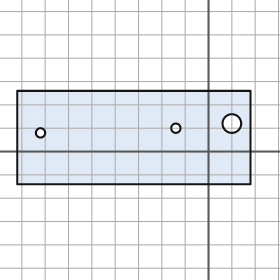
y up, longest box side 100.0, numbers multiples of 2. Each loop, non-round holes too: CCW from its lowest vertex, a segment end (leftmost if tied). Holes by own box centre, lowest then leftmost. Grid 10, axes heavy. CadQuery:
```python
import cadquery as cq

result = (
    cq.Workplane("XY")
    .moveTo(-82.0, -14.0)
    .lineTo(18.0, -14.0)
    .lineTo(18.0, 26.0)
    .lineTo(-82.0, 26.0)
    .close()
    .moveTo(-72.0, 8.0)
    .circle(2.0)
    .moveTo(-14.0, 10.0)
    .circle(2.0)
    .moveTo(10.0, 12.0)
    .circle(4.0)
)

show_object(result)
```